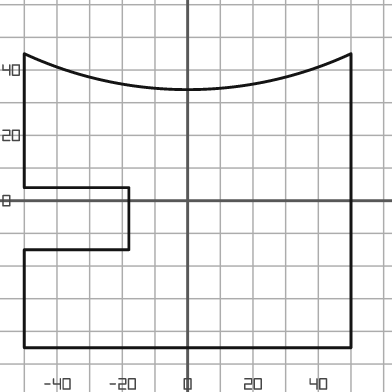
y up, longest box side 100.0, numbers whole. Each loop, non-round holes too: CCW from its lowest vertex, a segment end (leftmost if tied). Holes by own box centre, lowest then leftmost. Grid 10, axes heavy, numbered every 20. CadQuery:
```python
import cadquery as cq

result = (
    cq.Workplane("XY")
    .moveTo(-50.0, -45.0)
    .lineTo(50.0, -45.0)
    .lineTo(50.0, 45.0)
    .threePointArc((0.0, 34.0), (-50.0, 45.0))
    .lineTo(-50.0, 4.0)
    .lineTo(-18.0, 4.0)
    .lineTo(-18.0, -15.0)
    .lineTo(-50.0, -15.0)
    .close()
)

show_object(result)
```